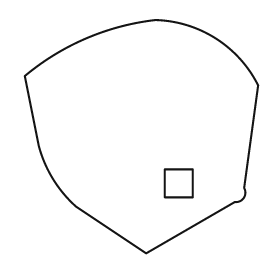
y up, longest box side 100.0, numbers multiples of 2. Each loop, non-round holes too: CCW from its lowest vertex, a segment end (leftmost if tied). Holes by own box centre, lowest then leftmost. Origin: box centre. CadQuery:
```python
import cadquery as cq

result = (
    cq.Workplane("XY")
    .moveTo(2.0, -50.0)
    .lineTo(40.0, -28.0)
    .threePointArc((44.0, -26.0), (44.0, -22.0))
    .lineTo(50.0, 22.0)
    .threePointArc((32.0, 42.0), (6.0, 50.0))
    .threePointArc((-24.0, 42.0), (-50.0, 26.0))
    .lineTo(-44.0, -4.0)
    .threePointArc((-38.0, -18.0), (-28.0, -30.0))
    .close()
    .moveTo(10.0, -26.0)
    .lineTo(22.0, -26.0)
    .lineTo(22.0, -14.0)
    .lineTo(10.0, -14.0)
    .close()
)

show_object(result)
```